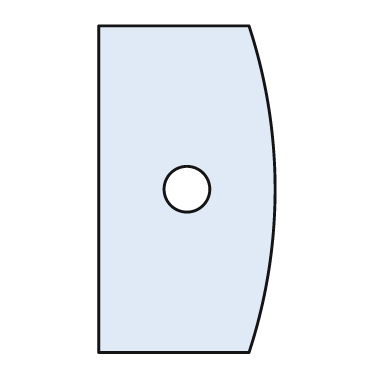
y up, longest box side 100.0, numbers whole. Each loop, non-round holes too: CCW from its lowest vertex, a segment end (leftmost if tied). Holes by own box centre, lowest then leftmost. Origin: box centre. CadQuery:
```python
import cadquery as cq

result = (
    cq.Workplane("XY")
    .moveTo(-27.0, -50.0)
    .lineTo(19.0, -50.0)
    .threePointArc((27.0, 0.0), (19.0, 50.0))
    .lineTo(-27.0, 50.0)
    .close()
    .moveTo(0.0, 0.0)
    .circle(7.0)
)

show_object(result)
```